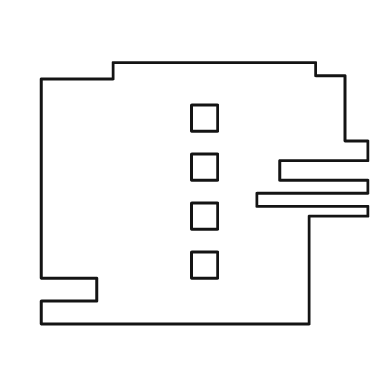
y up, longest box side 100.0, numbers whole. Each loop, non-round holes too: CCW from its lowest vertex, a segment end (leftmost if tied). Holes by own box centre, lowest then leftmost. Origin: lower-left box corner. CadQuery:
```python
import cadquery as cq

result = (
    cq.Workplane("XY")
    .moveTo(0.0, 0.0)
    .lineTo(82.0, 0.0)
    .lineTo(82.0, 33.0)
    .lineTo(100.0, 33.0)
    .lineTo(100.0, 36.0)
    .lineTo(66.0, 36.0)
    .lineTo(66.0, 40.0)
    .lineTo(100.0, 40.0)
    .lineTo(100.0, 44.0)
    .lineTo(73.0, 44.0)
    .lineTo(73.0, 50.0)
    .lineTo(100.0, 50.0)
    .lineTo(100.0, 56.0)
    .lineTo(93.0, 56.0)
    .lineTo(93.0, 76.0)
    .lineTo(84.0, 76.0)
    .lineTo(84.0, 80.0)
    .lineTo(22.0, 80.0)
    .lineTo(22.0, 75.0)
    .lineTo(0.0, 75.0)
    .lineTo(0.0, 14.0)
    .lineTo(17.0, 14.0)
    .lineTo(17.0, 7.0)
    .lineTo(0.0, 7.0)
    .close()
    .moveTo(46.0, 14.0)
    .lineTo(54.0, 14.0)
    .lineTo(54.0, 22.0)
    .lineTo(46.0, 22.0)
    .close()
    .moveTo(46.0, 29.0)
    .lineTo(54.0, 29.0)
    .lineTo(54.0, 37.0)
    .lineTo(46.0, 37.0)
    .close()
    .moveTo(46.0, 44.0)
    .lineTo(54.0, 44.0)
    .lineTo(54.0, 52.0)
    .lineTo(46.0, 52.0)
    .close()
    .moveTo(46.0, 59.0)
    .lineTo(54.0, 59.0)
    .lineTo(54.0, 67.0)
    .lineTo(46.0, 67.0)
    .close()
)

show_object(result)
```